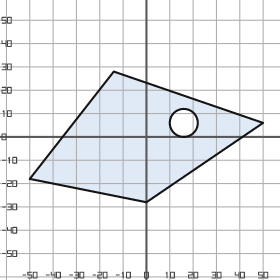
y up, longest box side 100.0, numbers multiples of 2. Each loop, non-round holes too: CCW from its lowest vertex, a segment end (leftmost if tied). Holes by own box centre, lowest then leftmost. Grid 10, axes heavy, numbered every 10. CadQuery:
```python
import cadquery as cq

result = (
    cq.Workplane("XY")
    .moveTo(0.0, -28.0)
    .lineTo(50.0, 6.0)
    .lineTo(-14.0, 28.0)
    .lineTo(-50.0, -18.0)
    .close()
    .moveTo(16.0, 6.0)
    .circle(6.0)
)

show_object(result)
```